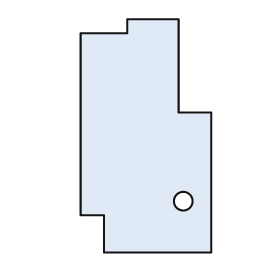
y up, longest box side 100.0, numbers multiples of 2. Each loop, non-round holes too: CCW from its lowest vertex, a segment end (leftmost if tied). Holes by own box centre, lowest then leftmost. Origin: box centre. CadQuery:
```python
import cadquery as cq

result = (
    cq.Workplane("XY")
    .moveTo(-18.0, -50.0)
    .lineTo(28.0, -50.0)
    .lineTo(28.0, 10.0)
    .lineTo(14.0, 10.0)
    .lineTo(14.0, 50.0)
    .lineTo(-8.0, 50.0)
    .lineTo(-8.0, 44.0)
    .lineTo(-28.0, 44.0)
    .lineTo(-28.0, -34.0)
    .lineTo(-18.0, -34.0)
    .close()
    .moveTo(16.0, -28.0)
    .circle(4.0)
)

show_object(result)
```